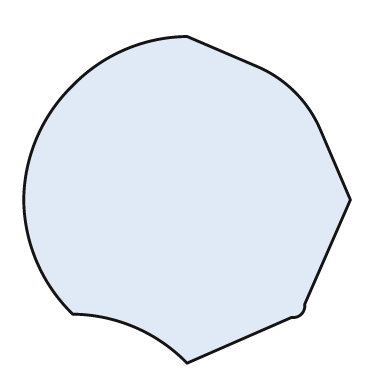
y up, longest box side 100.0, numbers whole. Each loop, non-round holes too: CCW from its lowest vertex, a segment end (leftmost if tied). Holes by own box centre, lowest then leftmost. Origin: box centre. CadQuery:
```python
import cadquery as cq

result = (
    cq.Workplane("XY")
    .moveTo(0.0, -50.0)
    .lineTo(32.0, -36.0)
    .threePointArc((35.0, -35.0), (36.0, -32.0))
    .lineTo(50.0, 0.0)
    .lineTo(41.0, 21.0)
    .threePointArc((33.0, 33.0), (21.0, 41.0))
    .lineTo(0.0, 50.0)
    .threePointArc((-19.0, 46.0), (-35.0, 35.0))
    .threePointArc((-46.0, 19.0), (-50.0, 0.0))
    .threePointArc((-46.0, -19.0), (-35.0, -35.0))
    .threePointArc((-16.0, -39.0), (0.0, -50.0))
    .close()
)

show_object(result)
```